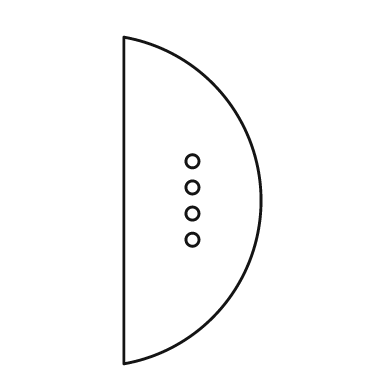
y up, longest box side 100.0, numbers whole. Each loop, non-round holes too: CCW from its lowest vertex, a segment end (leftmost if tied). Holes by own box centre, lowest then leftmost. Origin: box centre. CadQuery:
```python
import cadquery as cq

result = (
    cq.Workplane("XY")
    .moveTo(-21.0, -50.0)
    .threePointArc((21.0, 0.0), (-21.0, 50.0))
    .close()
    .moveTo(0.0, -12.0)
    .circle(2.0)
    .moveTo(0.0, -4.0)
    .circle(2.0)
    .moveTo(0.0, 4.0)
    .circle(2.0)
    .moveTo(0.0, 12.0)
    .circle(2.0)
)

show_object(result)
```